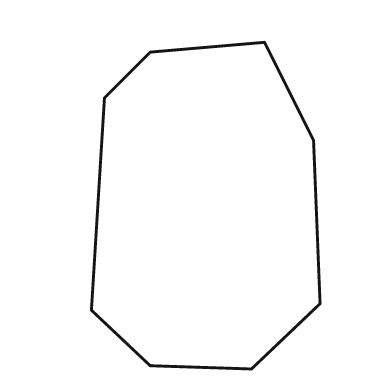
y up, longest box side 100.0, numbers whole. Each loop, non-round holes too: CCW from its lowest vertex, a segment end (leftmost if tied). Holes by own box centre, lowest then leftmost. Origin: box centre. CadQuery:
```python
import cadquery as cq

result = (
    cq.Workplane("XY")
    .moveTo(14.0, -50.0)
    .lineTo(35.0, -30.0)
    .lineTo(33.0, 20.0)
    .lineTo(18.0, 50.0)
    .lineTo(-17.0, 47.0)
    .lineTo(-31.0, 33.0)
    .lineTo(-35.0, -32.0)
    .lineTo(-17.0, -49.0)
    .close()
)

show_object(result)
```